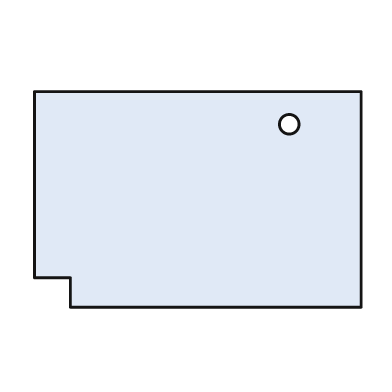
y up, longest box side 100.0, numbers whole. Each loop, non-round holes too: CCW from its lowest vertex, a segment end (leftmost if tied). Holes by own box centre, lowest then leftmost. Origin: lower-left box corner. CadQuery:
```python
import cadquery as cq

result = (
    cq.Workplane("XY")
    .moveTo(11.0, 0.0)
    .lineTo(100.0, 0.0)
    .lineTo(100.0, 66.0)
    .lineTo(0.0, 66.0)
    .lineTo(0.0, 9.0)
    .lineTo(11.0, 9.0)
    .close()
    .moveTo(78.0, 56.0)
    .circle(3.0)
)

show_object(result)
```